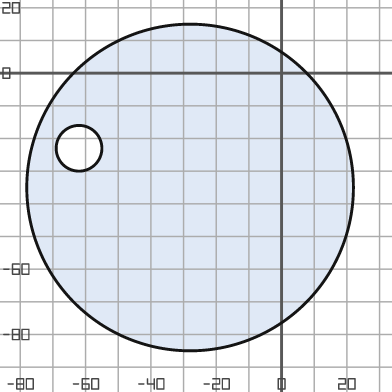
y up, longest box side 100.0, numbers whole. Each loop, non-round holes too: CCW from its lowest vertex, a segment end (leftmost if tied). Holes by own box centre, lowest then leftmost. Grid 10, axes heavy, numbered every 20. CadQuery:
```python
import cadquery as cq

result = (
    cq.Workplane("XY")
    .moveTo(-28.0, -35.0)
    .circle(50.0)
    .moveTo(-62.0, -23.0)
    .circle(7.0)
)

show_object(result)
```